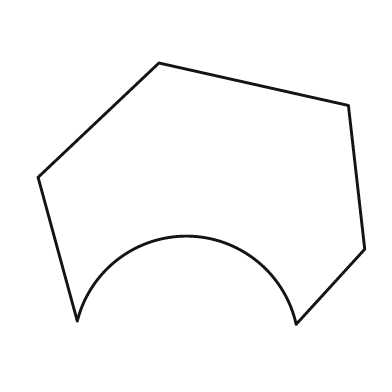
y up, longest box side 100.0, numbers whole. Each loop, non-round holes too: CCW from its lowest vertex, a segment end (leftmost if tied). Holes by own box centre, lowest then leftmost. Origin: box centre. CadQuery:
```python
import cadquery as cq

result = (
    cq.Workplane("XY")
    .moveTo(29.0, -40.0)
    .lineTo(50.0, -17.0)
    .lineTo(45.0, 27.0)
    .lineTo(-13.0, 40.0)
    .lineTo(-50.0, 5.0)
    .lineTo(-38.0, -39.0)
    .threePointArc((-4.0, -13.0), (29.0, -40.0))
    .close()
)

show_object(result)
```